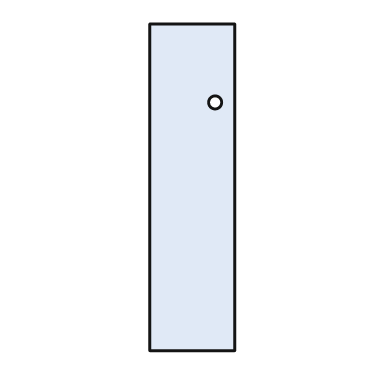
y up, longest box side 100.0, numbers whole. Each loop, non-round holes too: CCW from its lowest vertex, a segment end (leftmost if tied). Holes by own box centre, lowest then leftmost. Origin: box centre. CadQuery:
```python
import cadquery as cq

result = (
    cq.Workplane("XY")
    .moveTo(-13.0, -50.0)
    .lineTo(13.0, -50.0)
    .lineTo(13.0, 50.0)
    .lineTo(-13.0, 50.0)
    .close()
    .moveTo(7.0, 26.0)
    .circle(2.0)
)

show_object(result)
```